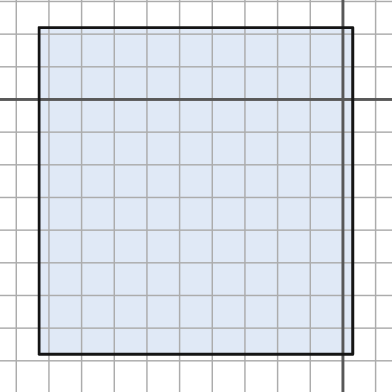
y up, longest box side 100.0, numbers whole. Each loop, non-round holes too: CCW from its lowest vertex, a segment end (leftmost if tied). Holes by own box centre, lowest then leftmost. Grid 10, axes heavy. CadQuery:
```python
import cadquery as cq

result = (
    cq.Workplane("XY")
    .moveTo(-93.0, -78.0)
    .lineTo(3.0, -78.0)
    .lineTo(3.0, 22.0)
    .lineTo(-93.0, 22.0)
    .close()
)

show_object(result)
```